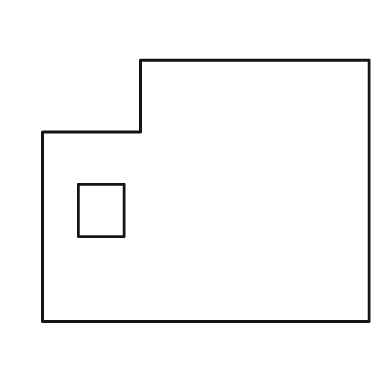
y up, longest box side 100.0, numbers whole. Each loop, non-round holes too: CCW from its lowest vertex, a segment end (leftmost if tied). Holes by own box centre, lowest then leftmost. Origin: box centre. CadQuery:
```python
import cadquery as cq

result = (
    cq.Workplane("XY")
    .moveTo(-50.0, -40.0)
    .lineTo(50.0, -40.0)
    .lineTo(50.0, 40.0)
    .lineTo(-20.0, 40.0)
    .lineTo(-20.0, 18.0)
    .lineTo(-50.0, 18.0)
    .close()
    .moveTo(-39.0, -14.0)
    .lineTo(-25.0, -14.0)
    .lineTo(-25.0, 2.0)
    .lineTo(-39.0, 2.0)
    .close()
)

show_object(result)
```